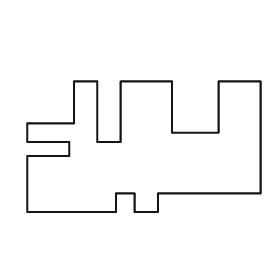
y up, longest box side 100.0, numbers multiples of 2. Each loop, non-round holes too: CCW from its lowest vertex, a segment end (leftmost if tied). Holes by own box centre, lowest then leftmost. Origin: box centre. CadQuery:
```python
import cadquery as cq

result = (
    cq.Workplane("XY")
    .moveTo(-50.0, -28.0)
    .lineTo(-12.0, -28.0)
    .lineTo(-12.0, -20.0)
    .lineTo(-4.0, -20.0)
    .lineTo(-4.0, -28.0)
    .lineTo(6.0, -28.0)
    .lineTo(6.0, -20.0)
    .lineTo(50.0, -20.0)
    .lineTo(50.0, 28.0)
    .lineTo(32.0, 28.0)
    .lineTo(32.0, 6.0)
    .lineTo(12.0, 6.0)
    .lineTo(12.0, 28.0)
    .lineTo(-10.0, 28.0)
    .lineTo(-10.0, 2.0)
    .lineTo(-20.0, 2.0)
    .lineTo(-20.0, 28.0)
    .lineTo(-30.0, 28.0)
    .lineTo(-30.0, 10.0)
    .lineTo(-50.0, 10.0)
    .lineTo(-50.0, 2.0)
    .lineTo(-32.0, 2.0)
    .lineTo(-32.0, -4.0)
    .lineTo(-50.0, -4.0)
    .close()
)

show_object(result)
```